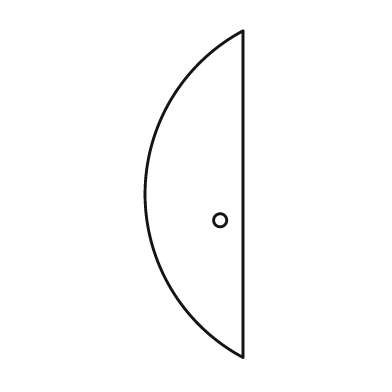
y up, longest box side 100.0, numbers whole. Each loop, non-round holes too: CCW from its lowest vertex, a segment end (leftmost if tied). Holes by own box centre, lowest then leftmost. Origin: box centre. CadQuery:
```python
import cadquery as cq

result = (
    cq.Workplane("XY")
    .moveTo(15.0, -50.0)
    .lineTo(15.0, 50.0)
    .threePointArc((-15.0, 0.0), (15.0, -50.0))
    .close()
    .moveTo(8.0, -8.0)
    .circle(2.0)
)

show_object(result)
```